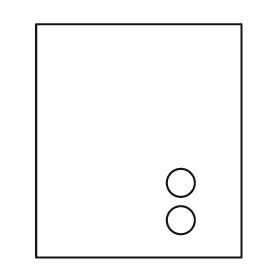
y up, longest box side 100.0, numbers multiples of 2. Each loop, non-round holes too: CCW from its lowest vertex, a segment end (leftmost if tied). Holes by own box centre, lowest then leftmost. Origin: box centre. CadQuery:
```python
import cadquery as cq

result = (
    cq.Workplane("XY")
    .moveTo(-44.0, -50.0)
    .lineTo(44.0, -50.0)
    .lineTo(44.0, 50.0)
    .lineTo(-44.0, 50.0)
    .close()
    .moveTo(18.0, -34.0)
    .circle(6.0)
    .moveTo(18.0, -18.0)
    .circle(6.0)
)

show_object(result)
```